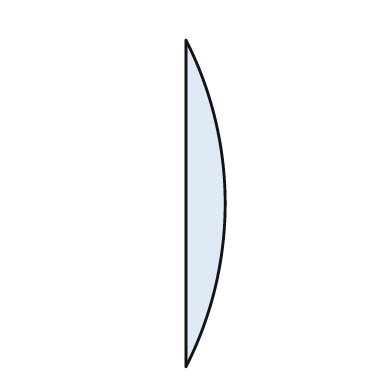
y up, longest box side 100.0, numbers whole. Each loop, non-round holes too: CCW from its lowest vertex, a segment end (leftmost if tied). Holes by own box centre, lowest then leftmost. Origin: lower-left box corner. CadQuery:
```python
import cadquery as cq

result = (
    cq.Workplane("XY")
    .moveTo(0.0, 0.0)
    .threePointArc((12.0, 50.0), (0.0, 100.0))
    .close()
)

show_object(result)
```